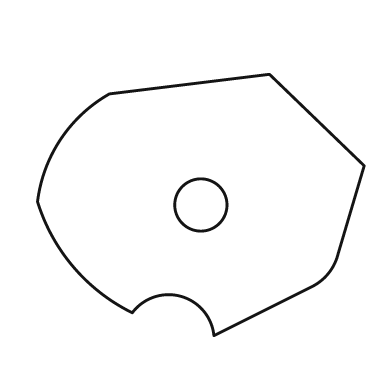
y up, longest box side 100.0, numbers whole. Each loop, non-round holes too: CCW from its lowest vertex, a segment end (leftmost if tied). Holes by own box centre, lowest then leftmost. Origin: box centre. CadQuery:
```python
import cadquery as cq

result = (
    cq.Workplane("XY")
    .moveTo(4.0, -40.0)
    .lineTo(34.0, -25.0)
    .threePointArc((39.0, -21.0), (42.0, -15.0))
    .lineTo(50.0, 12.0)
    .lineTo(21.0, 40.0)
    .lineTo(-28.0, 34.0)
    .threePointArc((-43.0, 20.0), (-50.0, 1.0))
    .threePointArc((-39.0, -19.0), (-21.0, -33.0))
    .threePointArc((-6.0, -28.0), (4.0, -40.0))
    .close()
    .moveTo(0.0, 0.0)
    .circle(8.0)
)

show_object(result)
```